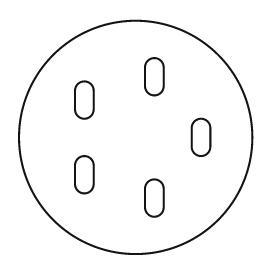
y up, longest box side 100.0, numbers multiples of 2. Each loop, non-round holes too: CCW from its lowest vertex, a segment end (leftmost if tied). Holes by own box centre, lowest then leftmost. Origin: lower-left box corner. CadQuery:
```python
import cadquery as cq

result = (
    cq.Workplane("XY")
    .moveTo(50.0, 50.0)
    .circle(50.0)
    .moveTo(54.0, 20.0)
    .threePointArc((58.0, 16.0), (62.0, 20.0))
    .lineTo(62.0, 28.0)
    .threePointArc((58.0, 32.0), (54.0, 28.0))
    .close()
    .moveTo(24.0, 30.0)
    .threePointArc((28.0, 26.0), (32.0, 30.0))
    .lineTo(32.0, 38.0)
    .threePointArc((28.0, 42.0), (24.0, 38.0))
    .close()
    .moveTo(74.0, 46.0)
    .threePointArc((78.0, 42.0), (82.0, 46.0))
    .lineTo(82.0, 54.0)
    .threePointArc((78.0, 58.0), (74.0, 54.0))
    .close()
    .moveTo(24.0, 62.0)
    .threePointArc((28.0, 58.0), (32.0, 62.0))
    .lineTo(32.0, 70.0)
    .threePointArc((28.0, 74.0), (24.0, 70.0))
    .close()
    .moveTo(54.0, 72.0)
    .threePointArc((58.0, 68.0), (62.0, 72.0))
    .lineTo(62.0, 80.0)
    .threePointArc((58.0, 84.0), (54.0, 80.0))
    .close()
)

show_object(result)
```